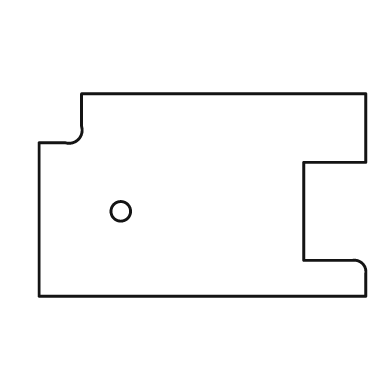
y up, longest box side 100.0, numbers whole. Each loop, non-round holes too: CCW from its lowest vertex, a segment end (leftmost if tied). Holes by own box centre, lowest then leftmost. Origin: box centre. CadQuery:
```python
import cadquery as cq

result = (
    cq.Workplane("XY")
    .moveTo(-50.0, -31.0)
    .lineTo(50.0, -31.0)
    .lineTo(50.0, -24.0)
    .threePointArc((49.0, -21.0), (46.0, -20.0))
    .lineTo(31.0, -20.0)
    .lineTo(31.0, 10.0)
    .lineTo(50.0, 10.0)
    .lineTo(50.0, 31.0)
    .lineTo(-37.0, 31.0)
    .lineTo(-37.0, 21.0)
    .threePointArc((-38.0, 17.0), (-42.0, 16.0))
    .lineTo(-50.0, 16.0)
    .close()
    .moveTo(-25.0, -5.0)
    .circle(3.0)
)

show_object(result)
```